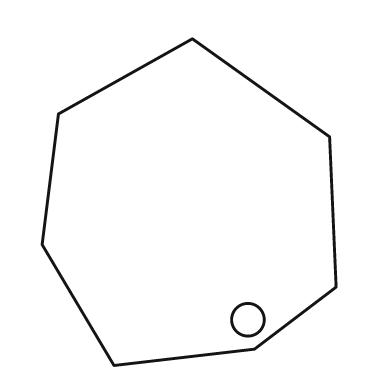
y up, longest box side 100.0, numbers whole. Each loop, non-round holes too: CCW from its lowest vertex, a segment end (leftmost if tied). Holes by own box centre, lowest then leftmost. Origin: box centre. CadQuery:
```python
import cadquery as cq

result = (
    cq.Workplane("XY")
    .moveTo(-23.0, -50.0)
    .lineTo(20.0, -45.0)
    .lineTo(45.0, -26.0)
    .lineTo(43.0, 20.0)
    .lineTo(1.0, 50.0)
    .lineTo(-40.0, 27.0)
    .lineTo(-45.0, -13.0)
    .close()
    .moveTo(18.0, -36.0)
    .circle(5.0)
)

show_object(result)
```